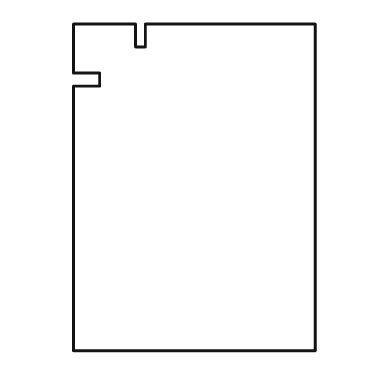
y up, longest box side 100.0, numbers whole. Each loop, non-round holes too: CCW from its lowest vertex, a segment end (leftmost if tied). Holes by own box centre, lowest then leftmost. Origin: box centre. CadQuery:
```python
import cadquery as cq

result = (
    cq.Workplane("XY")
    .moveTo(-37.0, -50.0)
    .lineTo(37.0, -50.0)
    .lineTo(37.0, 50.0)
    .lineTo(-15.0, 50.0)
    .lineTo(-15.0, 43.0)
    .lineTo(-18.0, 43.0)
    .lineTo(-18.0, 50.0)
    .lineTo(-37.0, 50.0)
    .lineTo(-37.0, 35.0)
    .lineTo(-29.0, 35.0)
    .lineTo(-29.0, 31.0)
    .lineTo(-37.0, 31.0)
    .close()
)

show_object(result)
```